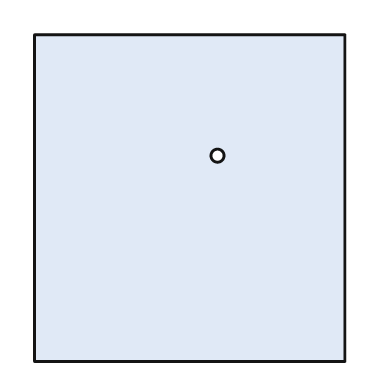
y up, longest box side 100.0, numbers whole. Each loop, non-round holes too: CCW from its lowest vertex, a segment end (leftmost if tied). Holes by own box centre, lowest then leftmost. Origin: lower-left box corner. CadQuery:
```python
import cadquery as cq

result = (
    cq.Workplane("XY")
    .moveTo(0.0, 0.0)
    .lineTo(95.0, 0.0)
    .lineTo(95.0, 100.0)
    .lineTo(0.0, 100.0)
    .close()
    .moveTo(56.0, 63.0)
    .circle(2.0)
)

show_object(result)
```